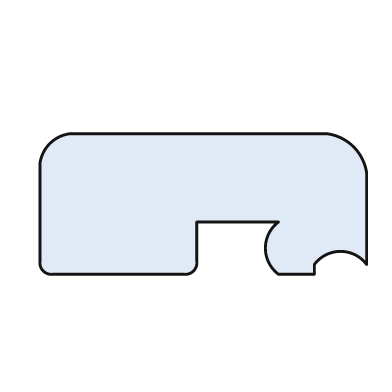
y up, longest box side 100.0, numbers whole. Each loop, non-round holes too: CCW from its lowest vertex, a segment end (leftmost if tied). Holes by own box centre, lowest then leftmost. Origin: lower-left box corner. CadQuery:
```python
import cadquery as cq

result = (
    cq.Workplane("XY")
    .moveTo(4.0, 0.0)
    .lineTo(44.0, 0.0)
    .threePointArc((47.0, 1.0), (48.0, 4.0))
    .lineTo(48.0, 16.0)
    .lineTo(73.0, 16.0)
    .threePointArc((69.0, 8.0), (73.0, 0.0))
    .lineTo(84.0, 0.0)
    .lineTo(84.0, 3.0)
    .threePointArc((92.0, 7.0), (100.0, 3.0))
    .lineTo(100.0, 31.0)
    .threePointArc((96.0, 39.0), (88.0, 43.0))
    .lineTo(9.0, 43.0)
    .threePointArc((3.0, 40.0), (0.0, 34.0))
    .lineTo(0.0, 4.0)
    .threePointArc((1.0, 1.0), (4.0, 0.0))
    .close()
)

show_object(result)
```